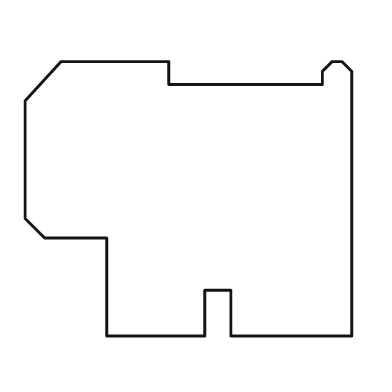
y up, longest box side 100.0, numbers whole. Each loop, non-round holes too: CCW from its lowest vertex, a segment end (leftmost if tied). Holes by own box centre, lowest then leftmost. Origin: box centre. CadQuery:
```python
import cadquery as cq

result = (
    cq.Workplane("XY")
    .moveTo(-25.0, -42.0)
    .lineTo(5.0, -42.0)
    .lineTo(5.0, -28.0)
    .lineTo(13.0, -28.0)
    .lineTo(13.0, -42.0)
    .lineTo(50.0, -42.0)
    .lineTo(50.0, 39.0)
    .lineTo(47.0, 42.0)
    .lineTo(44.0, 42.0)
    .lineTo(41.0, 39.0)
    .lineTo(41.0, 35.0)
    .lineTo(-6.0, 35.0)
    .lineTo(-6.0, 42.0)
    .lineTo(-39.0, 42.0)
    .lineTo(-50.0, 30.0)
    .lineTo(-50.0, -6.0)
    .lineTo(-44.0, -12.0)
    .lineTo(-25.0, -12.0)
    .close()
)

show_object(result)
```